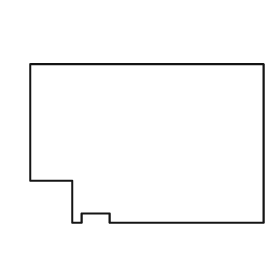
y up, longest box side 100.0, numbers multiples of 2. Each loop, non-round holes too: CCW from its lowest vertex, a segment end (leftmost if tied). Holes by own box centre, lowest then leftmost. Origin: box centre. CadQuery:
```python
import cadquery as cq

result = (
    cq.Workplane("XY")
    .moveTo(-32.0, -34.0)
    .lineTo(-28.0, -34.0)
    .lineTo(-28.0, -30.0)
    .lineTo(-16.0, -30.0)
    .lineTo(-16.0, -34.0)
    .lineTo(50.0, -34.0)
    .lineTo(50.0, 34.0)
    .lineTo(-50.0, 34.0)
    .lineTo(-50.0, -16.0)
    .lineTo(-32.0, -16.0)
    .close()
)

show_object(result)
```